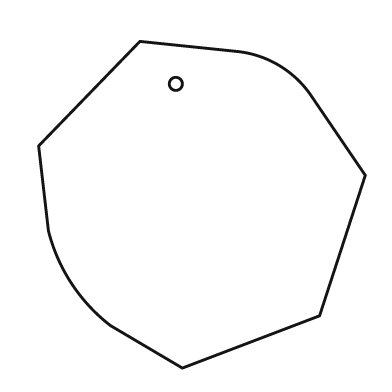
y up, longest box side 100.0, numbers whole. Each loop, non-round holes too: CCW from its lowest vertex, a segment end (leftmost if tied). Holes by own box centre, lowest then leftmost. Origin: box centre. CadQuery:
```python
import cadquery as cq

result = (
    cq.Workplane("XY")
    .moveTo(-6.0, -50.0)
    .lineTo(36.0, -34.0)
    .lineTo(50.0, 9.0)
    .lineTo(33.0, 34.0)
    .threePointArc((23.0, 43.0), (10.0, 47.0))
    .lineTo(-19.0, 50.0)
    .lineTo(-50.0, 18.0)
    .lineTo(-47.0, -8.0)
    .threePointArc((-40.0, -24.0), (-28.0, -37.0))
    .close()
    .moveTo(-8.0, 37.0)
    .circle(2.0)
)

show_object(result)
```